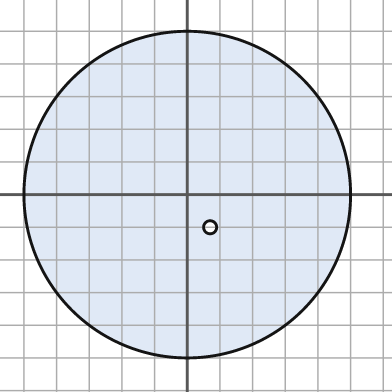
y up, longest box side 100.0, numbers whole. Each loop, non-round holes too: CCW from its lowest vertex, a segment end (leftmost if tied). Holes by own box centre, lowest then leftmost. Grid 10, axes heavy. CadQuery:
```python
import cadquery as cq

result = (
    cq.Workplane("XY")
    .moveTo(0.0, 0.0)
    .circle(50.0)
    .moveTo(7.0, -10.0)
    .circle(2.0)
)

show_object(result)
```